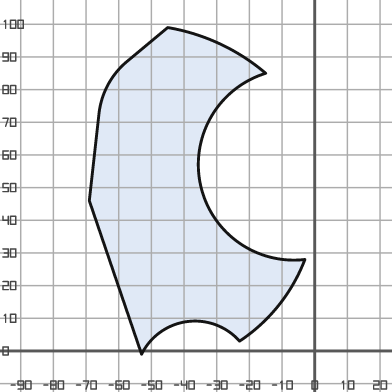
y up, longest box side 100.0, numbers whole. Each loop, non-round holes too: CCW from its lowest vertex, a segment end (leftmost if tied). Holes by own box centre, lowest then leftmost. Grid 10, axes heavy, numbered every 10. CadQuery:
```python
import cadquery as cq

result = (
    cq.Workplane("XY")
    .moveTo(-53.0, -1.0)
    .threePointArc((-39.0, 9.0), (-23.0, 3.0))
    .threePointArc((-11.0, 14.0), (-3.0, 28.0))
    .threePointArc((-35.0, 51.0), (-15.0, 85.0))
    .threePointArc((-29.0, 94.0), (-45.0, 99.0))
    .lineTo(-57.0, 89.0)
    .threePointArc((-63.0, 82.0), (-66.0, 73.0))
    .lineTo(-69.0, 46.0)
    .close()
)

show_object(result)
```